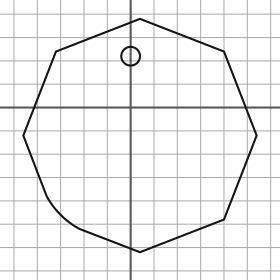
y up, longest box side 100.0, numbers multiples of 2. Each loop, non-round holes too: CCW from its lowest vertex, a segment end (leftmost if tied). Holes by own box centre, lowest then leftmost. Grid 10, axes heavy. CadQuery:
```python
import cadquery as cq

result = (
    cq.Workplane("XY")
    .moveTo(4.0, -62.0)
    .lineTo(40.0, -48.0)
    .lineTo(54.0, -12.0)
    .lineTo(40.0, 24.0)
    .lineTo(4.0, 38.0)
    .lineTo(-32.0, 24.0)
    .lineTo(-46.0, -12.0)
    .lineTo(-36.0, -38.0)
    .threePointArc((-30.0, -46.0), (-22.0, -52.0))
    .close()
    .moveTo(0.0, 22.0)
    .circle(4.0)
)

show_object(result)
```